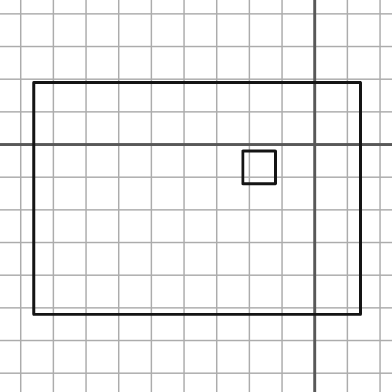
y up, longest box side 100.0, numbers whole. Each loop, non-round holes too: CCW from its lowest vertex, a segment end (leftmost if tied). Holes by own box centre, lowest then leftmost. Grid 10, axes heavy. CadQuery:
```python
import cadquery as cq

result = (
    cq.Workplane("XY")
    .moveTo(-86.0, -52.0)
    .lineTo(14.0, -52.0)
    .lineTo(14.0, 19.0)
    .lineTo(-86.0, 19.0)
    .close()
    .moveTo(-22.0, -12.0)
    .lineTo(-12.0, -12.0)
    .lineTo(-12.0, -2.0)
    .lineTo(-22.0, -2.0)
    .close()
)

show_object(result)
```